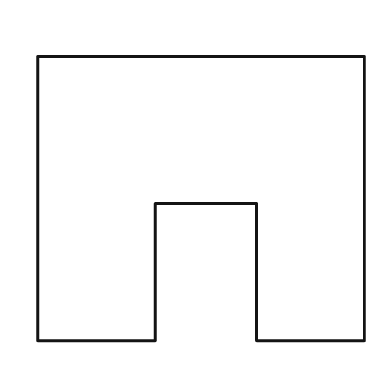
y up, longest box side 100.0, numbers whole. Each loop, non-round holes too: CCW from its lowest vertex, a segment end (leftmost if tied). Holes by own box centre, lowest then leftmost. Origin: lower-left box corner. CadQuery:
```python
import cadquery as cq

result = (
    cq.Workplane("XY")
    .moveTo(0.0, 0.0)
    .lineTo(36.0, 0.0)
    .lineTo(36.0, 42.0)
    .lineTo(67.0, 42.0)
    .lineTo(67.0, 0.0)
    .lineTo(100.0, 0.0)
    .lineTo(100.0, 87.0)
    .lineTo(0.0, 87.0)
    .close()
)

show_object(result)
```